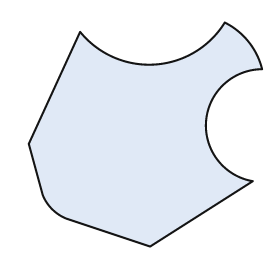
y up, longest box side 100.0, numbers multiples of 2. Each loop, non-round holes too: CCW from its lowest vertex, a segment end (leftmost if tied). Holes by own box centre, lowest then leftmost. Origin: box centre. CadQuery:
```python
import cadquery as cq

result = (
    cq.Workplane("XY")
    .moveTo(2.0, -48.0)
    .lineTo(46.0, -20.0)
    .threePointArc((26.0, 6.0), (50.0, 28.0))
    .threePointArc((44.0, 40.0), (34.0, 48.0))
    .threePointArc((4.0, 30.0), (-28.0, 44.0))
    .lineTo(-50.0, -4.0)
    .lineTo(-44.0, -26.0)
    .threePointArc((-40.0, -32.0), (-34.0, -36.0))
    .close()
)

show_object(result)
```